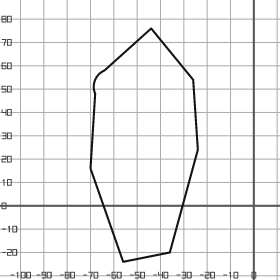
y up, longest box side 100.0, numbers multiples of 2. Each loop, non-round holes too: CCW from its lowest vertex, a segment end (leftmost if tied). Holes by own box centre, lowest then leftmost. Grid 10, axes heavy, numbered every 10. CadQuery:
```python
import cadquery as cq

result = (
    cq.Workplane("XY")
    .moveTo(-56.0, -24.0)
    .lineTo(-36.0, -20.0)
    .lineTo(-24.0, 24.0)
    .lineTo(-26.0, 54.0)
    .lineTo(-44.0, 76.0)
    .lineTo(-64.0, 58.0)
    .threePointArc((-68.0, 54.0), (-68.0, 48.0))
    .lineTo(-70.0, 16.0)
    .close()
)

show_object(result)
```